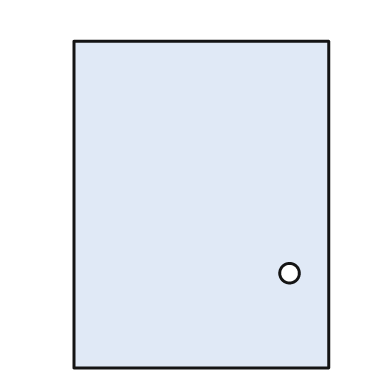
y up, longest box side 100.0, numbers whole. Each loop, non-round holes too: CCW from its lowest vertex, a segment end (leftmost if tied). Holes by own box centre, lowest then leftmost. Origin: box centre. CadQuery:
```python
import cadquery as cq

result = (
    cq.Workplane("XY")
    .moveTo(-39.0, -50.0)
    .lineTo(39.0, -50.0)
    .lineTo(39.0, 50.0)
    .lineTo(-39.0, 50.0)
    .close()
    .moveTo(27.0, -21.0)
    .circle(3.0)
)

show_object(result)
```